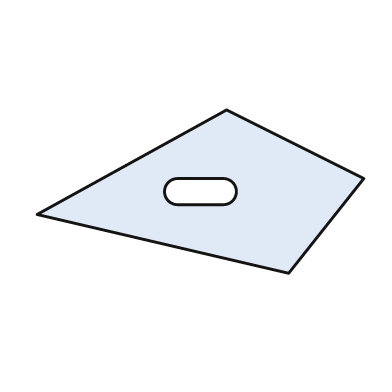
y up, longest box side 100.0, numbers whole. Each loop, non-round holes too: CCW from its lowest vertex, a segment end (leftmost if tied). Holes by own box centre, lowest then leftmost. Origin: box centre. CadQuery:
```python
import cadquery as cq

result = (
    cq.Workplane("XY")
    .moveTo(27.0, -25.0)
    .lineTo(50.0, 4.0)
    .lineTo(8.0, 25.0)
    .lineTo(-50.0, -7.0)
    .close()
    .moveTo(-7.0, -4.0)
    .lineTo(7.0, -4.0)
    .threePointArc((11.0, 0.0), (7.0, 4.0))
    .lineTo(-7.0, 4.0)
    .threePointArc((-11.0, 0.0), (-7.0, -4.0))
    .close()
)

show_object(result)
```